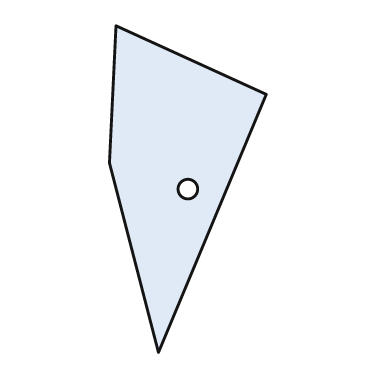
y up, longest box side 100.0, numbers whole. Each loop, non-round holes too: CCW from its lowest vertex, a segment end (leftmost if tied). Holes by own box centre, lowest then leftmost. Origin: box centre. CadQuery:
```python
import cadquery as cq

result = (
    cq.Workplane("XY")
    .moveTo(-9.0, -50.0)
    .lineTo(24.0, 29.0)
    .lineTo(-22.0, 50.0)
    .lineTo(-24.0, 8.0)
    .close()
    .moveTo(0.0, 0.0)
    .circle(3.0)
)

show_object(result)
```